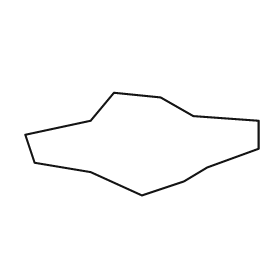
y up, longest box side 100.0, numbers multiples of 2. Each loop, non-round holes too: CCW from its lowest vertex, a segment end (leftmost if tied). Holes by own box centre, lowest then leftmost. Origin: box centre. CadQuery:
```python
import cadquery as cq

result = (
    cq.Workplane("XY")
    .moveTo(0.0, -22.0)
    .lineTo(18.0, -16.0)
    .lineTo(28.0, -10.0)
    .lineTo(50.0, -2.0)
    .lineTo(50.0, 10.0)
    .lineTo(22.0, 12.0)
    .lineTo(8.0, 20.0)
    .lineTo(-12.0, 22.0)
    .lineTo(-22.0, 10.0)
    .lineTo(-50.0, 4.0)
    .lineTo(-46.0, -8.0)
    .lineTo(-22.0, -12.0)
    .close()
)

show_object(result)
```